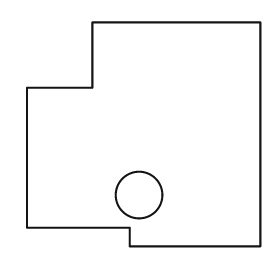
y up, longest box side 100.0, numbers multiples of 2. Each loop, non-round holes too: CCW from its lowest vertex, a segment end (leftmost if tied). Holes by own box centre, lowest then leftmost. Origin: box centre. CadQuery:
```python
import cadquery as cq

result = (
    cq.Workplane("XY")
    .moveTo(-6.0, -48.0)
    .lineTo(50.0, -48.0)
    .lineTo(50.0, 48.0)
    .lineTo(-22.0, 48.0)
    .lineTo(-22.0, 20.0)
    .lineTo(-50.0, 20.0)
    .lineTo(-50.0, -40.0)
    .lineTo(-6.0, -40.0)
    .close()
    .moveTo(-2.0, -26.0)
    .circle(10.0)
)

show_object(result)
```